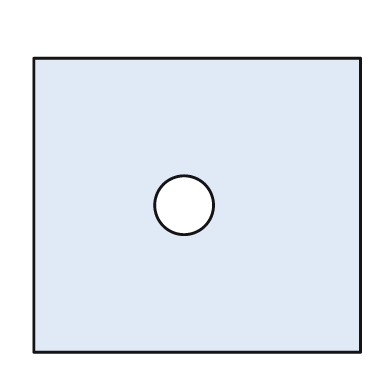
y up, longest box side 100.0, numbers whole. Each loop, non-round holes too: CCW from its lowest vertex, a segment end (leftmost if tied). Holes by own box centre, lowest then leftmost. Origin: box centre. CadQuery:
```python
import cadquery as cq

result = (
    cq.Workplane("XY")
    .moveTo(-50.0, -45.0)
    .lineTo(50.0, -45.0)
    .lineTo(50.0, 45.0)
    .lineTo(-50.0, 45.0)
    .close()
    .moveTo(-4.0, 0.0)
    .circle(9.0)
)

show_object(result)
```